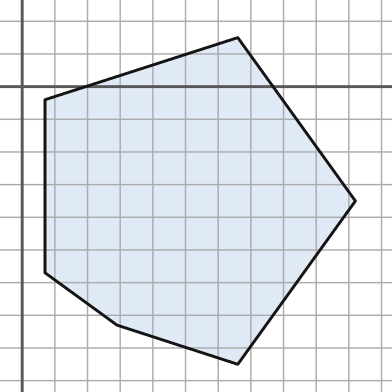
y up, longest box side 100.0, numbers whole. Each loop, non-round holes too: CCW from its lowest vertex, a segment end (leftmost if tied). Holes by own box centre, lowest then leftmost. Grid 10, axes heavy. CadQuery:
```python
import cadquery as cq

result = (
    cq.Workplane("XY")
    .moveTo(66.0, -85.0)
    .lineTo(102.0, -35.0)
    .lineTo(66.0, 15.0)
    .lineTo(7.0, -4.0)
    .lineTo(7.0, -57.0)
    .lineTo(29.0, -73.0)
    .close()
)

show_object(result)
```